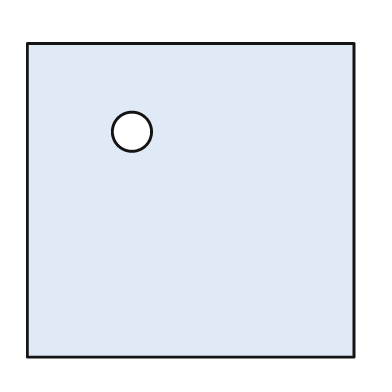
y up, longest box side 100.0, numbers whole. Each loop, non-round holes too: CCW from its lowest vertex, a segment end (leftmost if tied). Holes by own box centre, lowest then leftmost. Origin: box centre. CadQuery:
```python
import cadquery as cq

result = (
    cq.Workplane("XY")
    .moveTo(-50.0, -48.0)
    .lineTo(50.0, -48.0)
    .lineTo(50.0, 48.0)
    .lineTo(-50.0, 48.0)
    .close()
    .moveTo(-18.0, 21.0)
    .circle(6.0)
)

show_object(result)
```